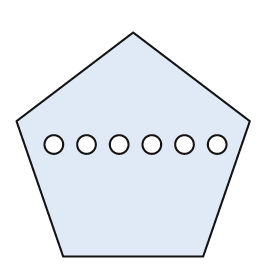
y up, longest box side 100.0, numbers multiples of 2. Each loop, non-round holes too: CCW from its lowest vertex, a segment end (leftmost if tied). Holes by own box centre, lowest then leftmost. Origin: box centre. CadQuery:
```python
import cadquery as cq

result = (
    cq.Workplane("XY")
    .moveTo(-30.0, -48.0)
    .lineTo(30.0, -48.0)
    .lineTo(50.0, 10.0)
    .lineTo(0.0, 48.0)
    .lineTo(-50.0, 10.0)
    .close()
    .moveTo(-34.0, 0.0)
    .circle(4.0)
    .moveTo(-20.0, 0.0)
    .circle(4.0)
    .moveTo(-6.0, 0.0)
    .circle(4.0)
    .moveTo(8.0, 0.0)
    .circle(4.0)
    .moveTo(22.0, 0.0)
    .circle(4.0)
    .moveTo(36.0, 0.0)
    .circle(4.0)
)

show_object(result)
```